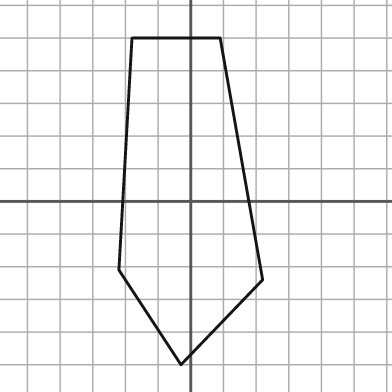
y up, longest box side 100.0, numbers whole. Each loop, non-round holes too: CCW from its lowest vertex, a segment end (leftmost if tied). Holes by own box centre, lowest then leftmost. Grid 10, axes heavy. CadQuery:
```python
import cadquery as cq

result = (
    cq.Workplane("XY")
    .moveTo(-3.0, -50.0)
    .lineTo(22.0, -24.0)
    .lineTo(9.0, 50.0)
    .lineTo(-18.0, 50.0)
    .lineTo(-22.0, -21.0)
    .close()
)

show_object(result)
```